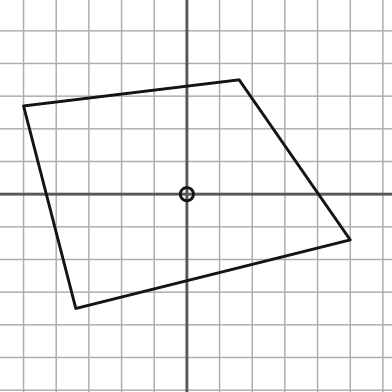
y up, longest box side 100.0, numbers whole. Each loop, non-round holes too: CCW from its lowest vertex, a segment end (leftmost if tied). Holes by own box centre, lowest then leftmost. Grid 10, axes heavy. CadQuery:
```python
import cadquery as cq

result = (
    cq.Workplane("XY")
    .moveTo(-34.0, -35.0)
    .lineTo(50.0, -14.0)
    .lineTo(16.0, 35.0)
    .lineTo(-50.0, 27.0)
    .close()
    .moveTo(0.0, 0.0)
    .circle(2.0)
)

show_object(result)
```